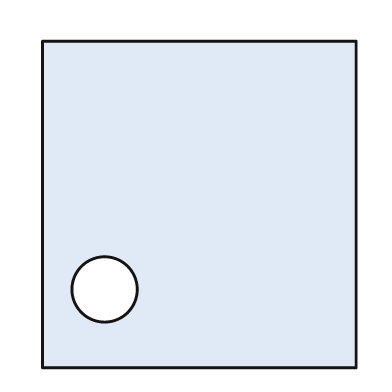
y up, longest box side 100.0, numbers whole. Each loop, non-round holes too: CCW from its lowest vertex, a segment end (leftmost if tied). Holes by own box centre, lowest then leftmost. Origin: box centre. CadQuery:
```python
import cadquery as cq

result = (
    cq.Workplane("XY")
    .moveTo(-48.0, -50.0)
    .lineTo(48.0, -50.0)
    .lineTo(48.0, 50.0)
    .lineTo(-48.0, 50.0)
    .close()
    .moveTo(-29.0, -26.0)
    .circle(10.0)
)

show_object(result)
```